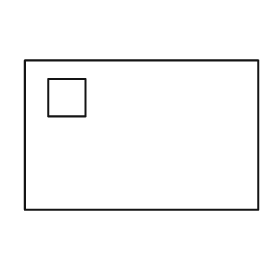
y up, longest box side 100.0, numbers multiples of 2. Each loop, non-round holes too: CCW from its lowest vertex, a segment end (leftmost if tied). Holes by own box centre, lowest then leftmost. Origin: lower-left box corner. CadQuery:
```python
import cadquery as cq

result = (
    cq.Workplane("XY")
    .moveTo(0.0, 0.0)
    .lineTo(100.0, 0.0)
    .lineTo(100.0, 64.0)
    .lineTo(0.0, 64.0)
    .close()
    .moveTo(10.0, 40.0)
    .lineTo(26.0, 40.0)
    .lineTo(26.0, 56.0)
    .lineTo(10.0, 56.0)
    .close()
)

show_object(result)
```